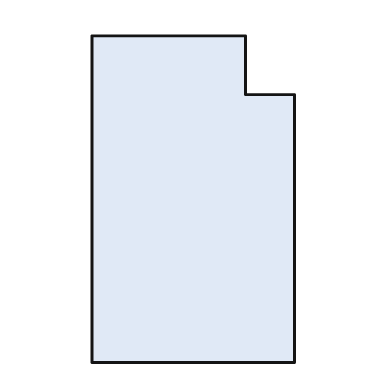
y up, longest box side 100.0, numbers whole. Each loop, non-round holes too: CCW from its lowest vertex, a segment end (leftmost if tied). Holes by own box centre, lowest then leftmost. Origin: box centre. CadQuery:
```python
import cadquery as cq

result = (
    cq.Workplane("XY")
    .moveTo(-31.0, -50.0)
    .lineTo(31.0, -50.0)
    .lineTo(31.0, 32.0)
    .lineTo(16.0, 32.0)
    .lineTo(16.0, 50.0)
    .lineTo(-31.0, 50.0)
    .close()
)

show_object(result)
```